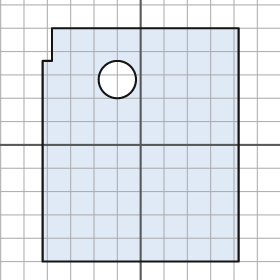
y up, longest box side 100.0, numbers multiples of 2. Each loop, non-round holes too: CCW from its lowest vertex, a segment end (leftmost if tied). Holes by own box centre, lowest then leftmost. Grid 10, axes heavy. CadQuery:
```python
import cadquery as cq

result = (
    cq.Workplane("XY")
    .moveTo(-42.0, -50.0)
    .lineTo(42.0, -50.0)
    .lineTo(42.0, 50.0)
    .lineTo(-38.0, 50.0)
    .lineTo(-38.0, 36.0)
    .lineTo(-42.0, 36.0)
    .close()
    .moveTo(-10.0, 28.0)
    .circle(8.0)
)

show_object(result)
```